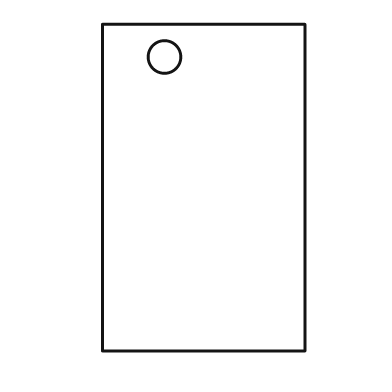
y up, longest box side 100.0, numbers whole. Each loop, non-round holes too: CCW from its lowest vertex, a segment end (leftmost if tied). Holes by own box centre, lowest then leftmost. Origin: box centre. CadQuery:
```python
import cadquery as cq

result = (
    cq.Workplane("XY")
    .moveTo(-31.0, -50.0)
    .lineTo(31.0, -50.0)
    .lineTo(31.0, 50.0)
    .lineTo(-31.0, 50.0)
    .close()
    .moveTo(-12.0, 40.0)
    .circle(5.0)
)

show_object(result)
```